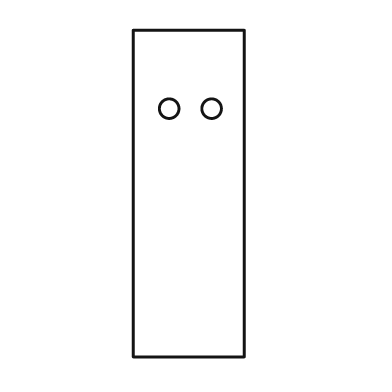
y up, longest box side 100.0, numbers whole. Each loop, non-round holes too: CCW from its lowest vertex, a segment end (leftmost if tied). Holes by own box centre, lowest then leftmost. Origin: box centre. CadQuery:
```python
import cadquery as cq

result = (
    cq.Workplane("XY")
    .moveTo(-17.0, -50.0)
    .lineTo(17.0, -50.0)
    .lineTo(17.0, 50.0)
    .lineTo(-17.0, 50.0)
    .close()
    .moveTo(-6.0, 26.0)
    .circle(3.0)
    .moveTo(7.0, 26.0)
    .circle(3.0)
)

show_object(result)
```